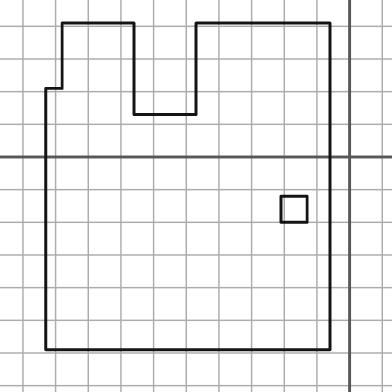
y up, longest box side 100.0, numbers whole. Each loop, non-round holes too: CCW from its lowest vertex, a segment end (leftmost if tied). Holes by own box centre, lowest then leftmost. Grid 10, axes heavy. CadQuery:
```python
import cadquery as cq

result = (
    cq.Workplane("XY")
    .moveTo(-93.0, -59.0)
    .lineTo(-6.0, -59.0)
    .lineTo(-6.0, 41.0)
    .lineTo(-47.0, 41.0)
    .lineTo(-47.0, 13.0)
    .lineTo(-66.0, 13.0)
    .lineTo(-66.0, 41.0)
    .lineTo(-88.0, 41.0)
    .lineTo(-88.0, 21.0)
    .lineTo(-93.0, 21.0)
    .close()
    .moveTo(-21.0, -20.0)
    .lineTo(-13.0, -20.0)
    .lineTo(-13.0, -12.0)
    .lineTo(-21.0, -12.0)
    .close()
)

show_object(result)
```